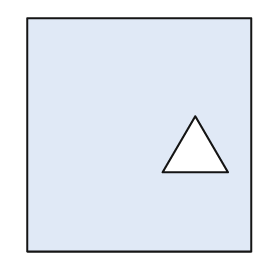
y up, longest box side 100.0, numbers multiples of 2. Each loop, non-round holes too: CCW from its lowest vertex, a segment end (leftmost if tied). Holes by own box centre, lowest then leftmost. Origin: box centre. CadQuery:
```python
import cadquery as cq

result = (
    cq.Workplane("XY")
    .moveTo(-48.0, -50.0)
    .lineTo(48.0, -50.0)
    .lineTo(48.0, 50.0)
    .lineTo(-48.0, 50.0)
    .close()
    .moveTo(10.0, -16.0)
    .lineTo(38.0, -16.0)
    .lineTo(24.0, 8.0)
    .close()
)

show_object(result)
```